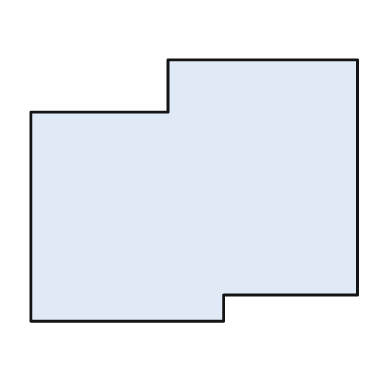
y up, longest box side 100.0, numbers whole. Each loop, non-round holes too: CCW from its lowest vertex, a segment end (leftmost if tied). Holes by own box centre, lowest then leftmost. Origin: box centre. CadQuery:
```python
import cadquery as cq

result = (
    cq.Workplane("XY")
    .moveTo(-50.0, -40.0)
    .lineTo(9.0, -40.0)
    .lineTo(9.0, -32.0)
    .lineTo(50.0, -32.0)
    .lineTo(50.0, 40.0)
    .lineTo(-8.0, 40.0)
    .lineTo(-8.0, 24.0)
    .lineTo(-50.0, 24.0)
    .close()
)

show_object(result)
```